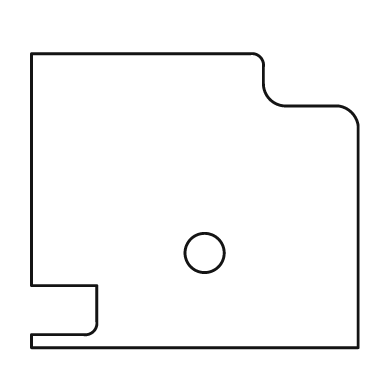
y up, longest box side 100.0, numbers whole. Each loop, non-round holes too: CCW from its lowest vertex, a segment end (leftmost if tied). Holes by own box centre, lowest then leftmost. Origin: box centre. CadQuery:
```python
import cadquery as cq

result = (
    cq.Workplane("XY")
    .moveTo(-50.0, -45.0)
    .lineTo(50.0, -45.0)
    .lineTo(50.0, 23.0)
    .threePointArc((48.0, 27.0), (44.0, 29.0))
    .lineTo(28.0, 29.0)
    .threePointArc((23.0, 31.0), (21.0, 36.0))
    .lineTo(21.0, 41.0)
    .threePointArc((20.0, 44.0), (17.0, 45.0))
    .lineTo(-50.0, 45.0)
    .lineTo(-50.0, -26.0)
    .lineTo(-30.0, -26.0)
    .lineTo(-30.0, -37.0)
    .threePointArc((-31.0, -40.0), (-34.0, -41.0))
    .lineTo(-50.0, -41.0)
    .close()
    .moveTo(3.0, -16.0)
    .circle(6.0)
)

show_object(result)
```